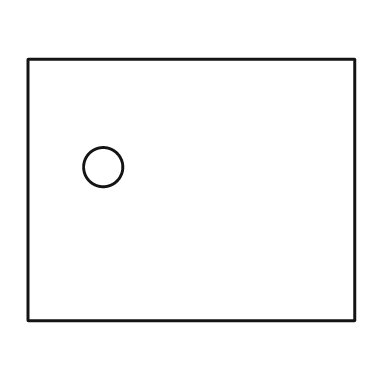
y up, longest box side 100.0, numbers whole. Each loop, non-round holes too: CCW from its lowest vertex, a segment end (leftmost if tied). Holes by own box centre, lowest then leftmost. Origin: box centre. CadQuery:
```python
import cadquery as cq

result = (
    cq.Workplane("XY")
    .moveTo(-50.0, -40.0)
    .lineTo(50.0, -40.0)
    .lineTo(50.0, 40.0)
    .lineTo(-50.0, 40.0)
    .close()
    .moveTo(-27.0, 7.0)
    .circle(6.0)
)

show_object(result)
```